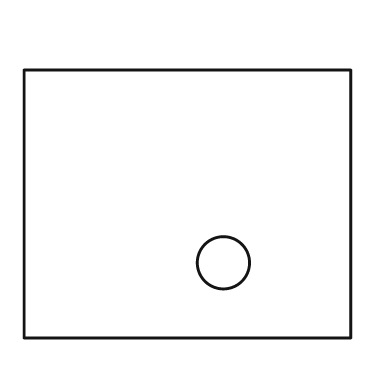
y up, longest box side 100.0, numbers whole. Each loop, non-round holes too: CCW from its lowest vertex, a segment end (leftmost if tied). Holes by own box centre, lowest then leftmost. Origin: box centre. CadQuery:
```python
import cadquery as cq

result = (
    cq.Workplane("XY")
    .moveTo(-50.0, -41.0)
    .lineTo(50.0, -41.0)
    .lineTo(50.0, 41.0)
    .lineTo(-50.0, 41.0)
    .close()
    .moveTo(11.0, -18.0)
    .circle(8.0)
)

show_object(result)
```